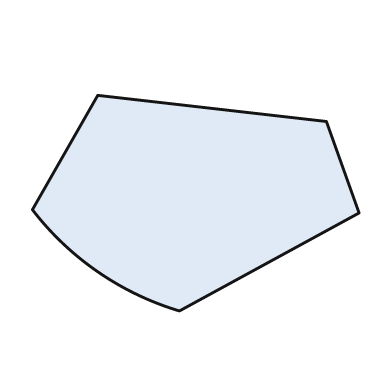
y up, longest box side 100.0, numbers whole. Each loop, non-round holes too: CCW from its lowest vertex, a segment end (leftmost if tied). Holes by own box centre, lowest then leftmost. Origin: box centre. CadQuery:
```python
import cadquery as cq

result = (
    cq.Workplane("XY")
    .moveTo(-5.0, -33.0)
    .lineTo(50.0, -3.0)
    .lineTo(40.0, 25.0)
    .lineTo(-30.0, 33.0)
    .lineTo(-50.0, -2.0)
    .threePointArc((-30.0, -21.0), (-5.0, -33.0))
    .close()
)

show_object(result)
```